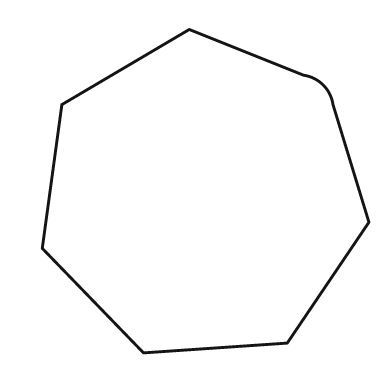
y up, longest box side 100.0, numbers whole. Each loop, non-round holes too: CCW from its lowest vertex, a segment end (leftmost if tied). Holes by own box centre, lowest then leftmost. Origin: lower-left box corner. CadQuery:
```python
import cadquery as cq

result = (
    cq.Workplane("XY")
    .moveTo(31.0, 0.0)
    .lineTo(75.0, 3.0)
    .lineTo(100.0, 40.0)
    .lineTo(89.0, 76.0)
    .threePointArc((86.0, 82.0), (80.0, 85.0))
    .lineTo(45.0, 99.0)
    .lineTo(6.0, 76.0)
    .lineTo(0.0, 32.0)
    .close()
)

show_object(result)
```